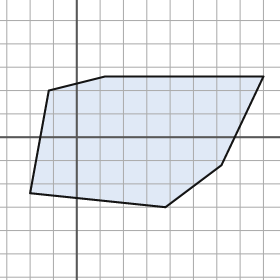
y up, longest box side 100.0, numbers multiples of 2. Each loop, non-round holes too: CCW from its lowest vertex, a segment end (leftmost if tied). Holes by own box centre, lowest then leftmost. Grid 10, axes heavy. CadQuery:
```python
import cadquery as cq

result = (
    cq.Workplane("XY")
    .moveTo(38.0, -30.0)
    .lineTo(62.0, -12.0)
    .lineTo(80.0, 26.0)
    .lineTo(12.0, 26.0)
    .lineTo(-12.0, 20.0)
    .lineTo(-20.0, -24.0)
    .close()
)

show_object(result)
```